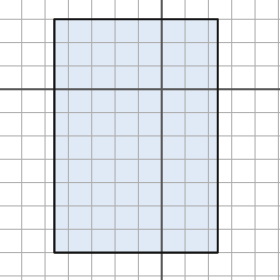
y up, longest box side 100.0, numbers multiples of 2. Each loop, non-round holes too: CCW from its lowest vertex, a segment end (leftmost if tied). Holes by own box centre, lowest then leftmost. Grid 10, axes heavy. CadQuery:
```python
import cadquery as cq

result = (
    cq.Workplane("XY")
    .moveTo(-46.0, -70.0)
    .lineTo(24.0, -70.0)
    .lineTo(24.0, 30.0)
    .lineTo(-46.0, 30.0)
    .close()
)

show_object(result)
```